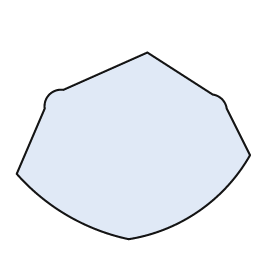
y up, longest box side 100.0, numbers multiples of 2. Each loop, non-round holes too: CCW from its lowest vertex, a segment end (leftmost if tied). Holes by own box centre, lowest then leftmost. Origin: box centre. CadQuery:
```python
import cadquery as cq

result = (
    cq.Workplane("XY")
    .moveTo(-2.0, -40.0)
    .threePointArc((28.0, -28.0), (50.0, -4.0))
    .lineTo(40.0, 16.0)
    .threePointArc((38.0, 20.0), (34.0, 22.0))
    .lineTo(6.0, 40.0)
    .lineTo(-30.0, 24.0)
    .threePointArc((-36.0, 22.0), (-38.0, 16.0))
    .lineTo(-50.0, -12.0)
    .threePointArc((-28.0, -30.0), (-2.0, -40.0))
    .close()
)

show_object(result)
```